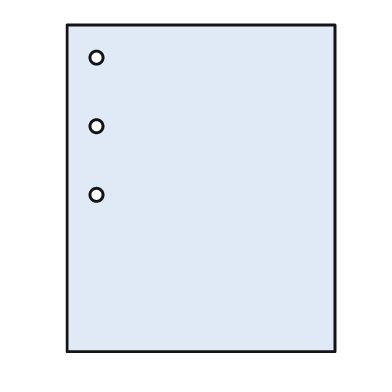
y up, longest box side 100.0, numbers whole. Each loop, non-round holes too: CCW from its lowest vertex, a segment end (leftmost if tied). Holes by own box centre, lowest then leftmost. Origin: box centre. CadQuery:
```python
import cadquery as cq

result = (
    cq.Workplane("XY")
    .moveTo(-41.0, -50.0)
    .lineTo(41.0, -50.0)
    .lineTo(41.0, 50.0)
    .lineTo(-41.0, 50.0)
    .close()
    .moveTo(-32.0, -2.0)
    .circle(2.0)
    .moveTo(-32.0, 19.0)
    .circle(2.0)
    .moveTo(-32.0, 40.0)
    .circle(2.0)
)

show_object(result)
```